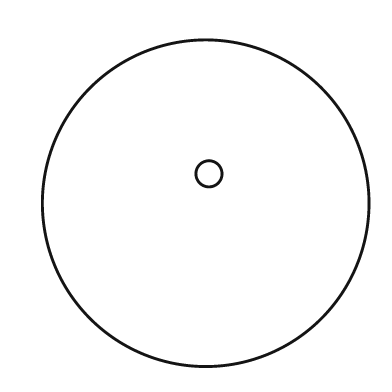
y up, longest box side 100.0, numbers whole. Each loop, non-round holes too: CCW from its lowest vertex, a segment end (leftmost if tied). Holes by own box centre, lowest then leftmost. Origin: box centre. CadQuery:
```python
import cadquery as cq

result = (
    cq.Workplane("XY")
    .moveTo(0.0, 0.0)
    .circle(50.0)
    .moveTo(1.0, 9.0)
    .circle(4.0)
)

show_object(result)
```